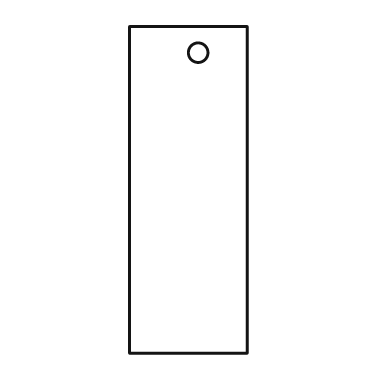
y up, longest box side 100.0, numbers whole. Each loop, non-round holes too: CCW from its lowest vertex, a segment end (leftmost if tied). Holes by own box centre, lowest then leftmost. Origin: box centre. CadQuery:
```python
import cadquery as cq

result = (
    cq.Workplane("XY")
    .moveTo(-18.0, -50.0)
    .lineTo(18.0, -50.0)
    .lineTo(18.0, 50.0)
    .lineTo(-18.0, 50.0)
    .close()
    .moveTo(3.0, 42.0)
    .circle(3.0)
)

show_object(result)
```